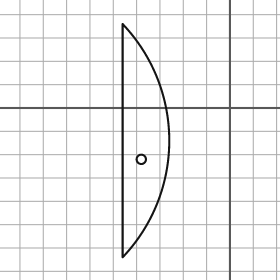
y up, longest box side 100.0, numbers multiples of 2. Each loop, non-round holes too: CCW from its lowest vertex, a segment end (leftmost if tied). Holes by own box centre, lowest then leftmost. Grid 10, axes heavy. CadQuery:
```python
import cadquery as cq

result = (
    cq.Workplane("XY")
    .moveTo(-46.0, -64.0)
    .threePointArc((-26.0, -14.0), (-46.0, 36.0))
    .close()
    .moveTo(-38.0, -22.0)
    .circle(2.0)
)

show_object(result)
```